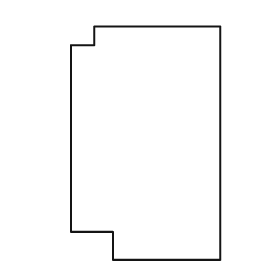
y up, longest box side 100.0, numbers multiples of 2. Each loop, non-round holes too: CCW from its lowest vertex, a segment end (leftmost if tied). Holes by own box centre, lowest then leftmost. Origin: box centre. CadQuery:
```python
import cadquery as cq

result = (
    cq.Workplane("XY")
    .moveTo(-14.0, -50.0)
    .lineTo(32.0, -50.0)
    .lineTo(32.0, 50.0)
    .lineTo(-22.0, 50.0)
    .lineTo(-22.0, 42.0)
    .lineTo(-32.0, 42.0)
    .lineTo(-32.0, -38.0)
    .lineTo(-14.0, -38.0)
    .close()
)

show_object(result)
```